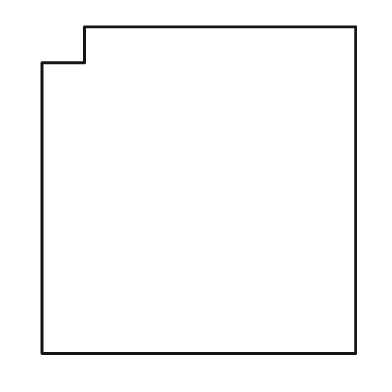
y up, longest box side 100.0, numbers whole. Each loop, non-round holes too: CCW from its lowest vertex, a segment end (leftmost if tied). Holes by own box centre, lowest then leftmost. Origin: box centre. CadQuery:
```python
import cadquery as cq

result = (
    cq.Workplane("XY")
    .moveTo(-48.0, -50.0)
    .lineTo(48.0, -50.0)
    .lineTo(48.0, 50.0)
    .lineTo(-35.0, 50.0)
    .lineTo(-35.0, 39.0)
    .lineTo(-48.0, 39.0)
    .close()
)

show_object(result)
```